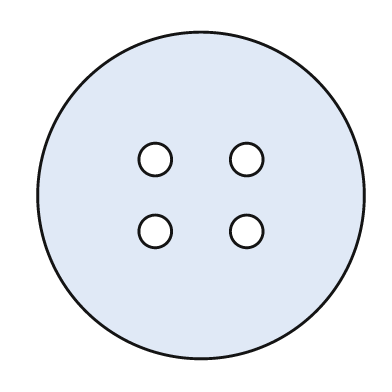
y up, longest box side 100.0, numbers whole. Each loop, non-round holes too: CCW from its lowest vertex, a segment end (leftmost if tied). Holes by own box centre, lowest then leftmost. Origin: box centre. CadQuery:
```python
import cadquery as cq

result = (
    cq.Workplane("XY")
    .moveTo(0.0, 0.0)
    .circle(50.0)
    .moveTo(-14.0, -11.0)
    .circle(5.0)
    .moveTo(14.0, -11.0)
    .circle(5.0)
    .moveTo(-14.0, 11.0)
    .circle(5.0)
    .moveTo(14.0, 11.0)
    .circle(5.0)
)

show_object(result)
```